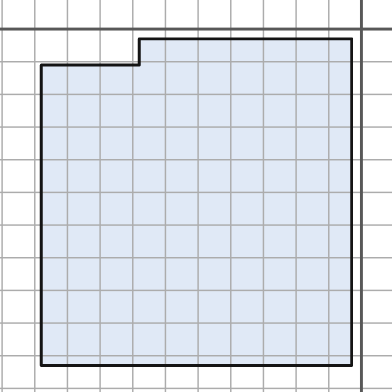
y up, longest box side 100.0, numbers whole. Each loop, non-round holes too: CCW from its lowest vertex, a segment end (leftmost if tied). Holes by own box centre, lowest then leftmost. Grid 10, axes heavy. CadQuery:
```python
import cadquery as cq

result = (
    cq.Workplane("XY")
    .moveTo(-98.0, -103.0)
    .lineTo(-3.0, -103.0)
    .lineTo(-3.0, -3.0)
    .lineTo(-68.0, -3.0)
    .lineTo(-68.0, -11.0)
    .lineTo(-98.0, -11.0)
    .close()
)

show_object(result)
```